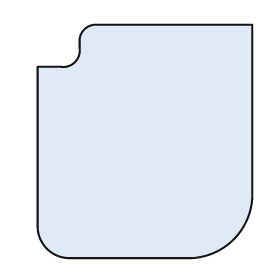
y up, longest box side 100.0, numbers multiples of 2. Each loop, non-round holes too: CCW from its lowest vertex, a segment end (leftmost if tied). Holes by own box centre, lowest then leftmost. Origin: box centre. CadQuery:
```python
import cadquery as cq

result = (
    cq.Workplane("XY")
    .moveTo(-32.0, -50.0)
    .lineTo(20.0, -50.0)
    .threePointArc((38.0, -42.0), (46.0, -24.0))
    .lineTo(46.0, 50.0)
    .lineTo(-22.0, 50.0)
    .threePointArc((-26.0, 48.0), (-28.0, 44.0))
    .lineTo(-28.0, 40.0)
    .threePointArc((-30.0, 34.0), (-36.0, 32.0))
    .lineTo(-46.0, 32.0)
    .lineTo(-46.0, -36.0)
    .threePointArc((-42.0, -46.0), (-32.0, -50.0))
    .close()
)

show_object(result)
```